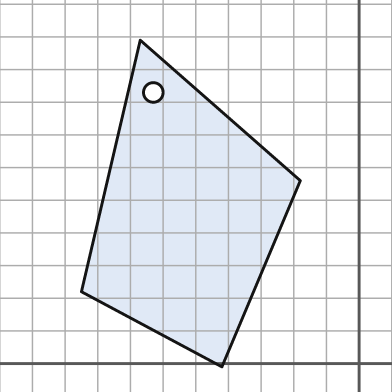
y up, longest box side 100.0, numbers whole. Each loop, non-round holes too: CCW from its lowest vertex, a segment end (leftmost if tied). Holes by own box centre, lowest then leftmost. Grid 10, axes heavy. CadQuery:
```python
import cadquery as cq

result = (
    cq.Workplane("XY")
    .moveTo(-42.0, -1.0)
    .lineTo(-18.0, 56.0)
    .lineTo(-67.0, 99.0)
    .lineTo(-85.0, 22.0)
    .close()
    .moveTo(-63.0, 83.0)
    .circle(3.0)
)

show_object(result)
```